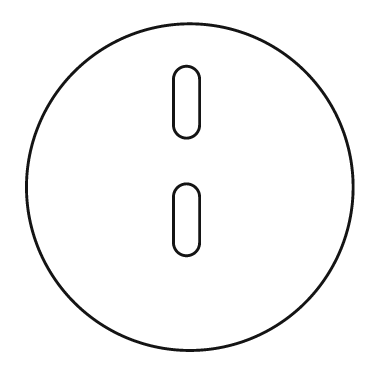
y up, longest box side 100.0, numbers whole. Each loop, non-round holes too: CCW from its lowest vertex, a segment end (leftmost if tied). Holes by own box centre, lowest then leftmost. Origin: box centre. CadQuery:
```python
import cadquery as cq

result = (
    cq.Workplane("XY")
    .moveTo(0.0, 0.0)
    .circle(50.0)
    .moveTo(-5.0, -17.0)
    .threePointArc((-1.0, -21.0), (3.0, -17.0))
    .lineTo(3.0, -3.0)
    .threePointArc((-1.0, 1.0), (-5.0, -3.0))
    .close()
    .moveTo(-5.0, 19.0)
    .threePointArc((-1.0, 15.0), (3.0, 19.0))
    .lineTo(3.0, 33.0)
    .threePointArc((-1.0, 37.0), (-5.0, 33.0))
    .close()
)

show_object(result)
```